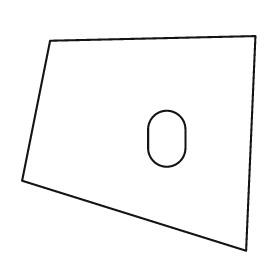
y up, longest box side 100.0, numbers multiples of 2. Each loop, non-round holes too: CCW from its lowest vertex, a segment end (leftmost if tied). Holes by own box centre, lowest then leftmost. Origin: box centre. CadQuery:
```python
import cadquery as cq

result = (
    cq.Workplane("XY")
    .moveTo(46.0, -46.0)
    .lineTo(50.0, 46.0)
    .lineTo(-38.0, 44.0)
    .lineTo(-50.0, -16.0)
    .close()
    .moveTo(4.0, -2.0)
    .threePointArc((12.0, -10.0), (20.0, -2.0))
    .lineTo(20.0, 6.0)
    .threePointArc((12.0, 14.0), (4.0, 6.0))
    .close()
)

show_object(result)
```